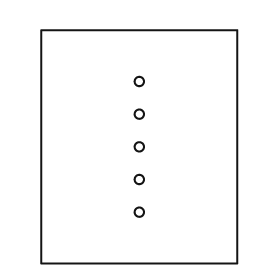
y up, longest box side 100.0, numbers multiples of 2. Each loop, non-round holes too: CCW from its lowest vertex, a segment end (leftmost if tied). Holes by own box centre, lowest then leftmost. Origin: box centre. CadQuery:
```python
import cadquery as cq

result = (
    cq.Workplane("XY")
    .moveTo(-42.0, -50.0)
    .lineTo(42.0, -50.0)
    .lineTo(42.0, 50.0)
    .lineTo(-42.0, 50.0)
    .close()
    .moveTo(0.0, -28.0)
    .circle(2.0)
    .moveTo(0.0, -14.0)
    .circle(2.0)
    .moveTo(0.0, 0.0)
    .circle(2.0)
    .moveTo(0.0, 14.0)
    .circle(2.0)
    .moveTo(0.0, 28.0)
    .circle(2.0)
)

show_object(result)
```